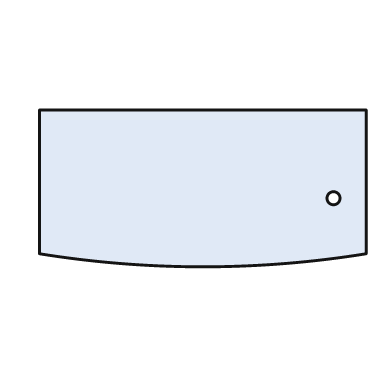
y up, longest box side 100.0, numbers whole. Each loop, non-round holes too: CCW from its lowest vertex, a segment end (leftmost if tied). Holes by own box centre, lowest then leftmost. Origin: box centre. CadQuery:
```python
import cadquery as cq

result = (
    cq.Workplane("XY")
    .moveTo(-50.0, -20.0)
    .threePointArc((0.0, -24.0), (50.0, -20.0))
    .lineTo(50.0, 24.0)
    .lineTo(-50.0, 24.0)
    .close()
    .moveTo(40.0, -3.0)
    .circle(2.0)
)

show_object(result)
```